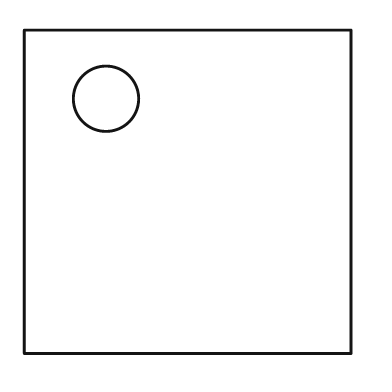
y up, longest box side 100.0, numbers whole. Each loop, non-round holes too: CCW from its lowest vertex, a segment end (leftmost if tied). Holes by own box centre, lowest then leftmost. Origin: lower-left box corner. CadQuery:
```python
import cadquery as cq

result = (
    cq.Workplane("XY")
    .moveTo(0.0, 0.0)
    .lineTo(100.0, 0.0)
    .lineTo(100.0, 99.0)
    .lineTo(0.0, 99.0)
    .close()
    .moveTo(25.0, 78.0)
    .circle(10.0)
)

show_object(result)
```